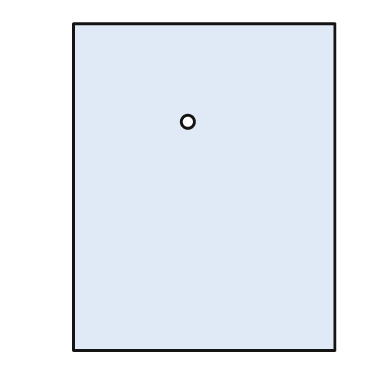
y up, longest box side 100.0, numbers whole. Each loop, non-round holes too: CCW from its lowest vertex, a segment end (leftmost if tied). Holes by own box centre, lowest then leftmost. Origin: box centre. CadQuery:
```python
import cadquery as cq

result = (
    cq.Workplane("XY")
    .moveTo(-40.0, -50.0)
    .lineTo(40.0, -50.0)
    .lineTo(40.0, 50.0)
    .lineTo(-40.0, 50.0)
    .close()
    .moveTo(-5.0, 20.0)
    .circle(2.0)
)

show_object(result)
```